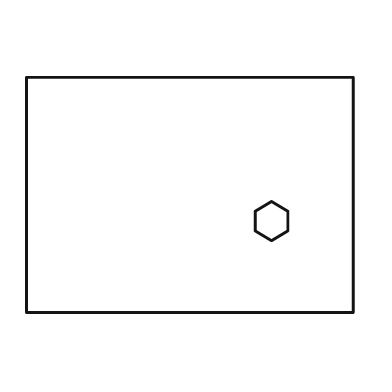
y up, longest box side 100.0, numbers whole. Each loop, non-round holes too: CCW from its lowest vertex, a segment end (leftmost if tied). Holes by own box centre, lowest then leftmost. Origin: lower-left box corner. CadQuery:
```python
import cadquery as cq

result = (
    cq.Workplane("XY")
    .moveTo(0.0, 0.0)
    .lineTo(100.0, 0.0)
    .lineTo(100.0, 72.0)
    .lineTo(0.0, 72.0)
    .close()
    .moveTo(75.0, 22.0)
    .lineTo(80.0, 25.0)
    .lineTo(80.0, 31.0)
    .lineTo(75.0, 34.0)
    .lineTo(70.0, 31.0)
    .lineTo(70.0, 25.0)
    .close()
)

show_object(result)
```